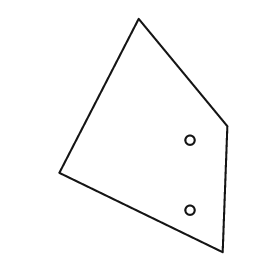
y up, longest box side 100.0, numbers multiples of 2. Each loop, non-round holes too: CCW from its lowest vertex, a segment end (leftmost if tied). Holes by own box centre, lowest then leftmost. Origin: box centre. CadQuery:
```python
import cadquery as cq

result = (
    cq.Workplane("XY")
    .moveTo(34.0, -50.0)
    .lineTo(36.0, 4.0)
    .lineTo(-2.0, 50.0)
    .lineTo(-36.0, -16.0)
    .close()
    .moveTo(20.0, -32.0)
    .circle(2.0)
    .moveTo(20.0, -2.0)
    .circle(2.0)
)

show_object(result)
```